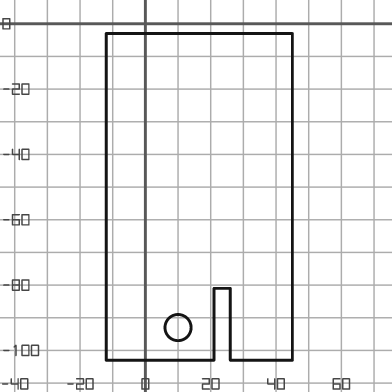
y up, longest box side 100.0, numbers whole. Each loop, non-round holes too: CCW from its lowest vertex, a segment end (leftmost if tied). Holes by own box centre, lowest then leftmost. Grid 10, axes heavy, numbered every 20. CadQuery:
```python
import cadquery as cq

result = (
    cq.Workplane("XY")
    .moveTo(-12.0, -103.0)
    .lineTo(21.0, -103.0)
    .lineTo(21.0, -81.0)
    .lineTo(26.0, -81.0)
    .lineTo(26.0, -103.0)
    .lineTo(45.0, -103.0)
    .lineTo(45.0, -3.0)
    .lineTo(-12.0, -3.0)
    .close()
    .moveTo(10.0, -93.0)
    .circle(4.0)
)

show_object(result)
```